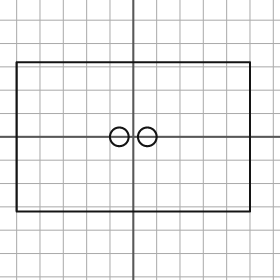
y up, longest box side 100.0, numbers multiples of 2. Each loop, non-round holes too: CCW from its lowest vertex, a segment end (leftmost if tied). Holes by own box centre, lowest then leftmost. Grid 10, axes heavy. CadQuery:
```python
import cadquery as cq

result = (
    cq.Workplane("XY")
    .moveTo(-50.0, -32.0)
    .lineTo(50.0, -32.0)
    .lineTo(50.0, 32.0)
    .lineTo(-50.0, 32.0)
    .close()
    .moveTo(-6.0, 0.0)
    .circle(4.0)
    .moveTo(6.0, 0.0)
    .circle(4.0)
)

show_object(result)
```